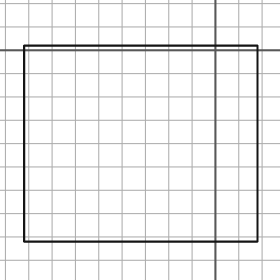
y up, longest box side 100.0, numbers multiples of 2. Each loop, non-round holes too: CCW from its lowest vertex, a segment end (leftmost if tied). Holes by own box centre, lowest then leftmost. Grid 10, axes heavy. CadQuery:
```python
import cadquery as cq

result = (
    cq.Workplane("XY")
    .moveTo(-82.0, -82.0)
    .lineTo(18.0, -82.0)
    .lineTo(18.0, 2.0)
    .lineTo(-82.0, 2.0)
    .close()
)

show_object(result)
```